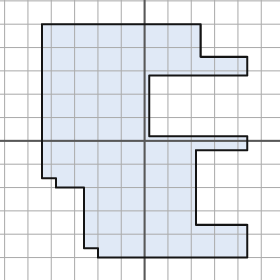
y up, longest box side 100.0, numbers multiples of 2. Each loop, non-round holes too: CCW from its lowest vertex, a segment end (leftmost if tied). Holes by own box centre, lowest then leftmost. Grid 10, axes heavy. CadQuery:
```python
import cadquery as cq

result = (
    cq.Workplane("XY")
    .moveTo(-20.0, -50.0)
    .lineTo(44.0, -50.0)
    .lineTo(44.0, -36.0)
    .lineTo(22.0, -36.0)
    .lineTo(22.0, -4.0)
    .lineTo(44.0, -4.0)
    .lineTo(44.0, 2.0)
    .lineTo(2.0, 2.0)
    .lineTo(2.0, 28.0)
    .lineTo(44.0, 28.0)
    .lineTo(44.0, 36.0)
    .lineTo(24.0, 36.0)
    .lineTo(24.0, 50.0)
    .lineTo(-44.0, 50.0)
    .lineTo(-44.0, -16.0)
    .lineTo(-38.0, -16.0)
    .lineTo(-38.0, -20.0)
    .lineTo(-26.0, -20.0)
    .lineTo(-26.0, -46.0)
    .lineTo(-20.0, -46.0)
    .close()
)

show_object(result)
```